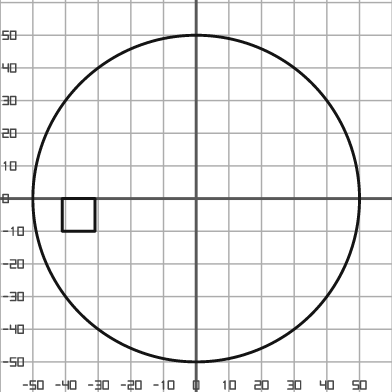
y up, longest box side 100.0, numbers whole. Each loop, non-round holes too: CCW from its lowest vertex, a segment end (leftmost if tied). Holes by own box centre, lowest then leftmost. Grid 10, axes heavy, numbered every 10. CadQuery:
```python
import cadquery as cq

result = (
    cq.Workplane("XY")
    .moveTo(0.0, 0.0)
    .circle(50.0)
    .moveTo(-41.0, -10.0)
    .lineTo(-31.0, -10.0)
    .lineTo(-31.0, 0.0)
    .lineTo(-41.0, 0.0)
    .close()
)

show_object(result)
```